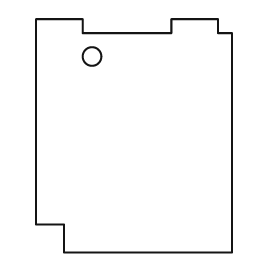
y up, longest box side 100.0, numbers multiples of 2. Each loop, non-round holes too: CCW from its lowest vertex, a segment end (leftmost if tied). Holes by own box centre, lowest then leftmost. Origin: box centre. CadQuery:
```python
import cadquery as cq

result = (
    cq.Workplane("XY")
    .moveTo(-30.0, -50.0)
    .lineTo(42.0, -50.0)
    .lineTo(42.0, 44.0)
    .lineTo(36.0, 44.0)
    .lineTo(36.0, 50.0)
    .lineTo(16.0, 50.0)
    .lineTo(16.0, 44.0)
    .lineTo(-22.0, 44.0)
    .lineTo(-22.0, 50.0)
    .lineTo(-42.0, 50.0)
    .lineTo(-42.0, -38.0)
    .lineTo(-30.0, -38.0)
    .close()
    .moveTo(-18.0, 34.0)
    .circle(4.0)
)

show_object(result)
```